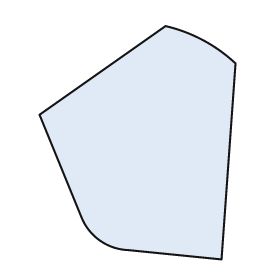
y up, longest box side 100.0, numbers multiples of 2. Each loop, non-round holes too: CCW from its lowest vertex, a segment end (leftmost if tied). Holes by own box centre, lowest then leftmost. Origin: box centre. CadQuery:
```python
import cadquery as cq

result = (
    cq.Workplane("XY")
    .moveTo(36.0, -50.0)
    .lineTo(42.0, 34.0)
    .threePointArc((28.0, 44.0), (12.0, 50.0))
    .lineTo(-42.0, 12.0)
    .lineTo(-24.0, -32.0)
    .threePointArc((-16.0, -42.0), (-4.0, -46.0))
    .close()
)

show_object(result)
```